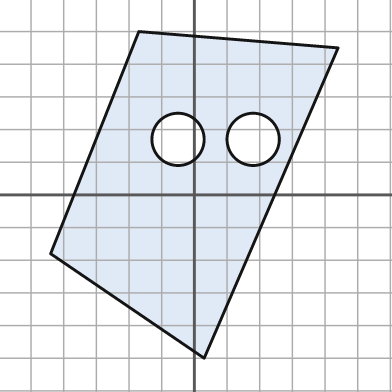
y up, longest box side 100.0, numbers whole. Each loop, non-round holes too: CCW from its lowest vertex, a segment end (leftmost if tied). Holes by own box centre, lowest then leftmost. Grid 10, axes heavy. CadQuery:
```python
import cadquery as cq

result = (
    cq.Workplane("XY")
    .moveTo(3.0, -50.0)
    .lineTo(44.0, 45.0)
    .lineTo(-17.0, 50.0)
    .lineTo(-44.0, -18.0)
    .close()
    .moveTo(-5.0, 17.0)
    .circle(8.0)
    .moveTo(18.0, 17.0)
    .circle(8.0)
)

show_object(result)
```